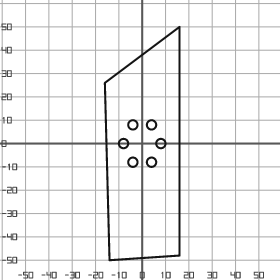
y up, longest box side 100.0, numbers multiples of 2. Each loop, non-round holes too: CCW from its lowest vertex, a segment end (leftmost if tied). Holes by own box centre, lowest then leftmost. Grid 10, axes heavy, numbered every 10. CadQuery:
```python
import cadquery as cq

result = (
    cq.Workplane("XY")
    .moveTo(-14.0, -50.0)
    .lineTo(16.0, -48.0)
    .lineTo(16.0, 50.0)
    .lineTo(-16.0, 26.0)
    .close()
    .moveTo(-4.0, -8.0)
    .circle(2.0)
    .moveTo(4.0, -8.0)
    .circle(2.0)
    .moveTo(-8.0, 0.0)
    .circle(2.0)
    .moveTo(8.0, 0.0)
    .circle(2.0)
    .moveTo(-4.0, 8.0)
    .circle(2.0)
    .moveTo(4.0, 8.0)
    .circle(2.0)
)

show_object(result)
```